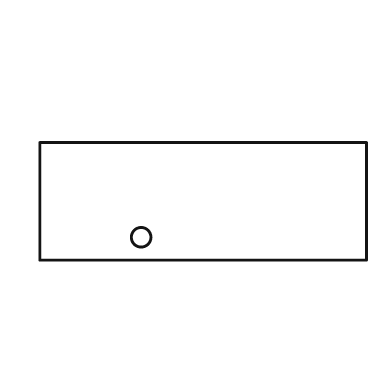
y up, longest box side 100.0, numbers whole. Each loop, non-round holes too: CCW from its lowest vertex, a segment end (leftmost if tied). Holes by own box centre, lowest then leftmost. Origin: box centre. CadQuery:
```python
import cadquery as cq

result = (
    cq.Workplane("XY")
    .moveTo(-50.0, -18.0)
    .lineTo(50.0, -18.0)
    .lineTo(50.0, 18.0)
    .lineTo(-50.0, 18.0)
    .close()
    .moveTo(-19.0, -11.0)
    .circle(3.0)
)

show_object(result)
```